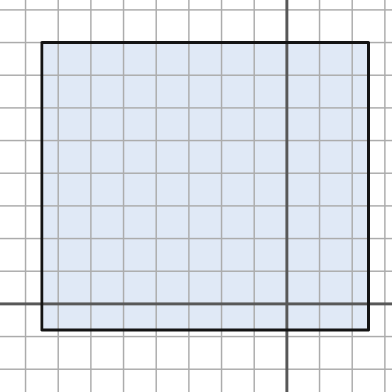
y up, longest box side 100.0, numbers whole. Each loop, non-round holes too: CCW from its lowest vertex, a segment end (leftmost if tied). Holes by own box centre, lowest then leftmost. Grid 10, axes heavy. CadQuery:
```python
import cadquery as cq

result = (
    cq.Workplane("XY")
    .moveTo(-75.0, -8.0)
    .lineTo(25.0, -8.0)
    .lineTo(25.0, 80.0)
    .lineTo(-75.0, 80.0)
    .close()
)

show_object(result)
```